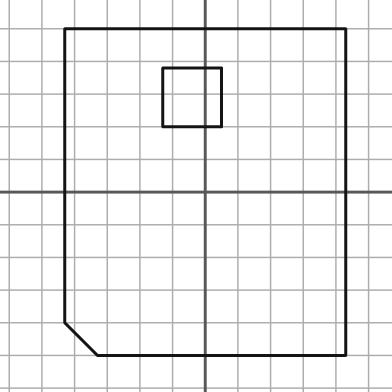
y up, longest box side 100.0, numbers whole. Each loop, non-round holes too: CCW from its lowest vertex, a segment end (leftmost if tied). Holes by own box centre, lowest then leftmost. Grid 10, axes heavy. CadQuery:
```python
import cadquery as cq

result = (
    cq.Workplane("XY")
    .moveTo(-33.0, -50.0)
    .lineTo(43.0, -50.0)
    .lineTo(43.0, 50.0)
    .lineTo(-43.0, 50.0)
    .lineTo(-43.0, -40.0)
    .close()
    .moveTo(-13.0, 20.0)
    .lineTo(5.0, 20.0)
    .lineTo(5.0, 38.0)
    .lineTo(-13.0, 38.0)
    .close()
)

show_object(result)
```